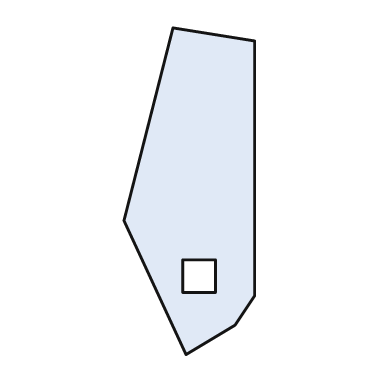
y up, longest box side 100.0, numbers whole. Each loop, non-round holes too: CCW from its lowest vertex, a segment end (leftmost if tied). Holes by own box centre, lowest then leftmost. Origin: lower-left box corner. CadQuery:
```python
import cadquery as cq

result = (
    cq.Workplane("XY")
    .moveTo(19.0, 0.0)
    .lineTo(34.0, 9.0)
    .lineTo(40.0, 18.0)
    .lineTo(40.0, 96.0)
    .lineTo(15.0, 100.0)
    .lineTo(0.0, 41.0)
    .close()
    .moveTo(18.0, 19.0)
    .lineTo(28.0, 19.0)
    .lineTo(28.0, 29.0)
    .lineTo(18.0, 29.0)
    .close()
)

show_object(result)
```